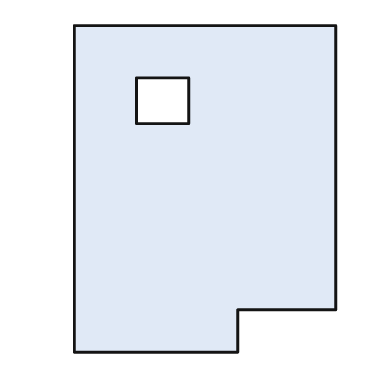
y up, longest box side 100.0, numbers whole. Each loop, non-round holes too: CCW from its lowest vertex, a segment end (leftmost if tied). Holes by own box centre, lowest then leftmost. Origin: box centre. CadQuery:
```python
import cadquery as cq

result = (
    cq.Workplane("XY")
    .moveTo(-40.0, -50.0)
    .lineTo(10.0, -50.0)
    .lineTo(10.0, -37.0)
    .lineTo(40.0, -37.0)
    .lineTo(40.0, 50.0)
    .lineTo(-40.0, 50.0)
    .close()
    .moveTo(-21.0, 20.0)
    .lineTo(-5.0, 20.0)
    .lineTo(-5.0, 34.0)
    .lineTo(-21.0, 34.0)
    .close()
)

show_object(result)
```